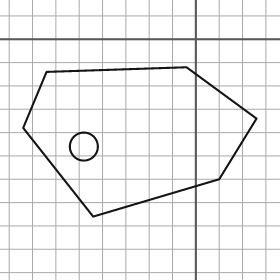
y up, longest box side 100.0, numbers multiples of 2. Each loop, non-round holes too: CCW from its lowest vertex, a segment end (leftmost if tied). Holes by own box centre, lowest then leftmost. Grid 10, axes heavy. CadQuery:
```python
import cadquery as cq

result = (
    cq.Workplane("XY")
    .moveTo(-44.0, -76.0)
    .lineTo(10.0, -60.0)
    .lineTo(26.0, -34.0)
    .lineTo(-4.0, -12.0)
    .lineTo(-64.0, -14.0)
    .lineTo(-74.0, -38.0)
    .close()
    .moveTo(-48.0, -46.0)
    .circle(6.0)
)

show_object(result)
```